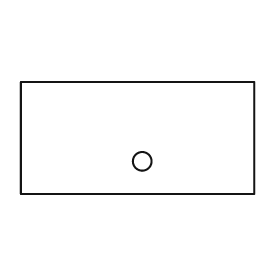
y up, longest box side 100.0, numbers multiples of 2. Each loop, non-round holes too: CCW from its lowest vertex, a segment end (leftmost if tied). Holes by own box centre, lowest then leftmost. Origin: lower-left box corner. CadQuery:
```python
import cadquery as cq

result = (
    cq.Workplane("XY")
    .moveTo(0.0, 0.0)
    .lineTo(100.0, 0.0)
    .lineTo(100.0, 48.0)
    .lineTo(0.0, 48.0)
    .close()
    .moveTo(52.0, 14.0)
    .circle(4.0)
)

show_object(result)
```